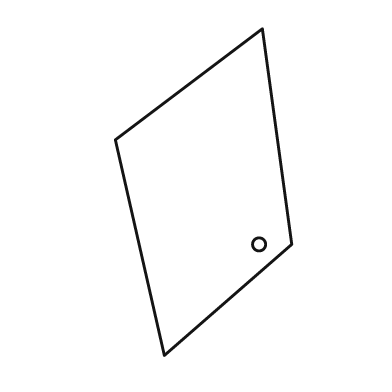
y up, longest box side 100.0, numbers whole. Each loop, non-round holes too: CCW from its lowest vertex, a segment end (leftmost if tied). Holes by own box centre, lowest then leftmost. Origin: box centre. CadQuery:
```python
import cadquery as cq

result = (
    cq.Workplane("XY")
    .moveTo(-12.0, -50.0)
    .lineTo(27.0, -16.0)
    .lineTo(18.0, 50.0)
    .lineTo(-27.0, 16.0)
    .close()
    .moveTo(17.0, -16.0)
    .circle(2.0)
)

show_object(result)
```